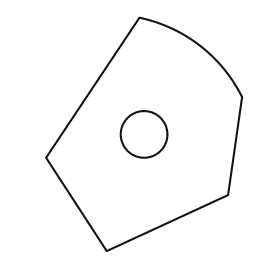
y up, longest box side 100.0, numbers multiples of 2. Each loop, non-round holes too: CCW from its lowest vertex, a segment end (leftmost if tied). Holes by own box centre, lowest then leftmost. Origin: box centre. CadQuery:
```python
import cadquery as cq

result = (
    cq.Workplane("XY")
    .moveTo(-16.0, -50.0)
    .lineTo(36.0, -26.0)
    .lineTo(42.0, 16.0)
    .threePointArc((24.0, 38.0), (-2.0, 50.0))
    .lineTo(-42.0, -10.0)
    .close()
    .moveTo(0.0, 0.0)
    .circle(10.0)
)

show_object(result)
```